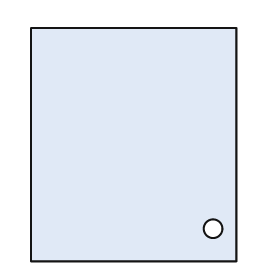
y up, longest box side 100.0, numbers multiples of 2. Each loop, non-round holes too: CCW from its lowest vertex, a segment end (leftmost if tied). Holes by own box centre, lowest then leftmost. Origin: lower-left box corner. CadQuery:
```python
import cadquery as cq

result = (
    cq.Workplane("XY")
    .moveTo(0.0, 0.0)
    .lineTo(88.0, 0.0)
    .lineTo(88.0, 100.0)
    .lineTo(0.0, 100.0)
    .close()
    .moveTo(78.0, 14.0)
    .circle(4.0)
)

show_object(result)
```